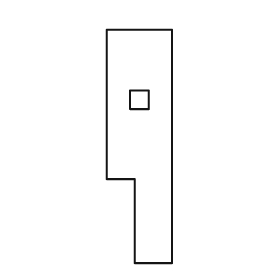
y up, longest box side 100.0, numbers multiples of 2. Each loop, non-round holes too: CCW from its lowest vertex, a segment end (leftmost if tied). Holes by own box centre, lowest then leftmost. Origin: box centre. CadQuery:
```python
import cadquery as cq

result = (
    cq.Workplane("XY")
    .moveTo(-2.0, -50.0)
    .lineTo(14.0, -50.0)
    .lineTo(14.0, 50.0)
    .lineTo(-14.0, 50.0)
    .lineTo(-14.0, -14.0)
    .lineTo(-2.0, -14.0)
    .close()
    .moveTo(-4.0, 16.0)
    .lineTo(4.0, 16.0)
    .lineTo(4.0, 24.0)
    .lineTo(-4.0, 24.0)
    .close()
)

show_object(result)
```